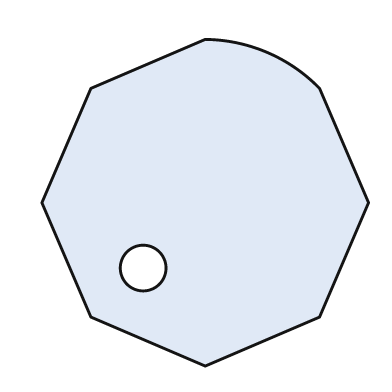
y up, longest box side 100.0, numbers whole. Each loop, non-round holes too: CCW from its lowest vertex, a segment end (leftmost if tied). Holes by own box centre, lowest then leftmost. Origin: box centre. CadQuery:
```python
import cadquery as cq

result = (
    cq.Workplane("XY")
    .moveTo(0.0, -50.0)
    .lineTo(35.0, -35.0)
    .lineTo(50.0, 0.0)
    .lineTo(35.0, 35.0)
    .threePointArc((19.0, 46.0), (0.0, 50.0))
    .lineTo(-35.0, 35.0)
    .lineTo(-50.0, 0.0)
    .lineTo(-35.0, -35.0)
    .close()
    .moveTo(-19.0, -20.0)
    .circle(7.0)
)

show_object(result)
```